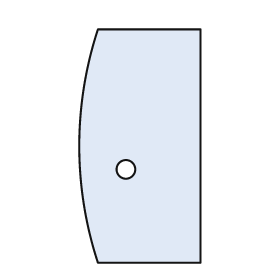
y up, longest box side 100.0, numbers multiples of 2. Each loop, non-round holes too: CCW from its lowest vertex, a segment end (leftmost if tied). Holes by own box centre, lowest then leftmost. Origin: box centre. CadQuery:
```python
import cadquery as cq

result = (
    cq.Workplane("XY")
    .moveTo(-18.0, -50.0)
    .lineTo(26.0, -50.0)
    .lineTo(26.0, 50.0)
    .lineTo(-18.0, 50.0)
    .threePointArc((-26.0, 0.0), (-18.0, -50.0))
    .close()
    .moveTo(-6.0, -10.0)
    .circle(4.0)
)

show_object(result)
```